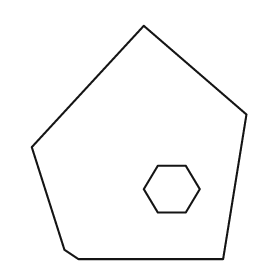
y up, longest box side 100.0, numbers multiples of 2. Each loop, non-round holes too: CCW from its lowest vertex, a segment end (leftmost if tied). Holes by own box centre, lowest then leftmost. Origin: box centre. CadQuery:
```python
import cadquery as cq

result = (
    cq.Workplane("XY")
    .moveTo(-26.0, -50.0)
    .lineTo(36.0, -50.0)
    .lineTo(46.0, 12.0)
    .lineTo(2.0, 50.0)
    .lineTo(-46.0, -2.0)
    .lineTo(-32.0, -46.0)
    .close()
    .moveTo(8.0, -30.0)
    .lineTo(20.0, -30.0)
    .lineTo(26.0, -20.0)
    .lineTo(20.0, -10.0)
    .lineTo(8.0, -10.0)
    .lineTo(2.0, -20.0)
    .close()
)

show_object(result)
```